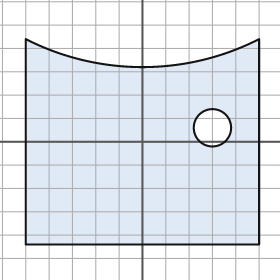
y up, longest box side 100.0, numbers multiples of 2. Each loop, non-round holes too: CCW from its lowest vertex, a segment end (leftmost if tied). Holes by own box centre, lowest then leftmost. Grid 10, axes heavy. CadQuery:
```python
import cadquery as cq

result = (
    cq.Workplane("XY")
    .moveTo(-50.0, -44.0)
    .lineTo(50.0, -44.0)
    .lineTo(50.0, 44.0)
    .threePointArc((0.0, 32.0), (-50.0, 44.0))
    .close()
    .moveTo(30.0, 6.0)
    .circle(8.0)
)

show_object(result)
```